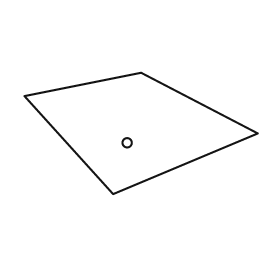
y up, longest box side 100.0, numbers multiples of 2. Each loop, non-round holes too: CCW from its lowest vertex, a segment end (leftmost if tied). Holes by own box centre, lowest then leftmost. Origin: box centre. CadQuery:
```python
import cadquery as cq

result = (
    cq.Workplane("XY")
    .moveTo(-12.0, -26.0)
    .lineTo(50.0, 0.0)
    .lineTo(0.0, 26.0)
    .lineTo(-50.0, 16.0)
    .close()
    .moveTo(-6.0, -4.0)
    .circle(2.0)
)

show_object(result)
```